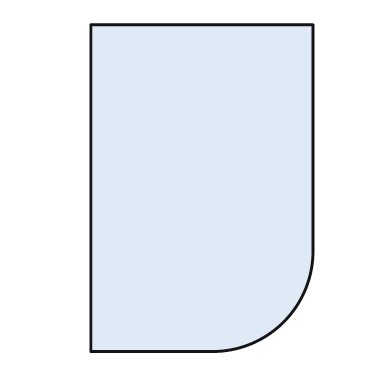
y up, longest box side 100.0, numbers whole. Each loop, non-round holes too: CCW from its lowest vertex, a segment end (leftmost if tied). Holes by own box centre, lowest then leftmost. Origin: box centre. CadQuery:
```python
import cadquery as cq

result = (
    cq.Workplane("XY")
    .moveTo(-34.0, -50.0)
    .lineTo(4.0, -50.0)
    .threePointArc((25.0, -41.0), (34.0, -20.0))
    .lineTo(34.0, 50.0)
    .lineTo(-34.0, 50.0)
    .close()
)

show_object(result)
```